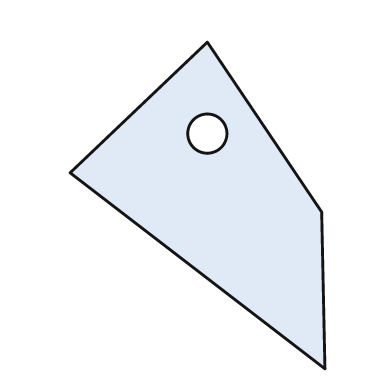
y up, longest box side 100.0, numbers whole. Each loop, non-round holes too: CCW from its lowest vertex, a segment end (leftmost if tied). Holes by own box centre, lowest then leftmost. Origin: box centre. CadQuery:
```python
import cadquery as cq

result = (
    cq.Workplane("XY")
    .moveTo(39.0, -50.0)
    .lineTo(38.0, -2.0)
    .lineTo(3.0, 50.0)
    .lineTo(-39.0, 10.0)
    .close()
    .moveTo(3.0, 22.0)
    .circle(6.0)
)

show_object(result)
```